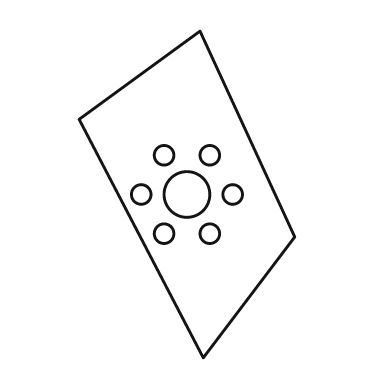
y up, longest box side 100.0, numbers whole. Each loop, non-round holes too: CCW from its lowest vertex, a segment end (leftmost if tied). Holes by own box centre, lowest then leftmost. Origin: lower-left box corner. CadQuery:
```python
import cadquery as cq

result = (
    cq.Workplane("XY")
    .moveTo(38.0, 0.0)
    .lineTo(66.0, 37.0)
    .lineTo(37.0, 100.0)
    .lineTo(0.0, 73.0)
    .close()
    .moveTo(26.0, 38.0)
    .circle(3.0)
    .moveTo(40.0, 38.0)
    .circle(3.0)
    .moveTo(19.0, 50.0)
    .circle(3.0)
    .moveTo(33.0, 50.0)
    .circle(7.0)
    .moveTo(47.0, 50.0)
    .circle(3.0)
    .moveTo(26.0, 62.0)
    .circle(3.0)
    .moveTo(40.0, 62.0)
    .circle(3.0)
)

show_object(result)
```